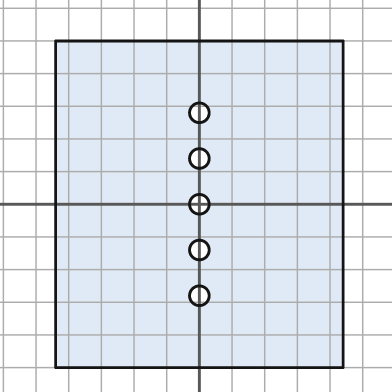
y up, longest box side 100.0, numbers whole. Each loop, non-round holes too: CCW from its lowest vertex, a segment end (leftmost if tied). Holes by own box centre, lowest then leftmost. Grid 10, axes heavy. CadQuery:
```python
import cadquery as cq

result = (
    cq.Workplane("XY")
    .moveTo(-44.0, -50.0)
    .lineTo(44.0, -50.0)
    .lineTo(44.0, 50.0)
    .lineTo(-44.0, 50.0)
    .close()
    .moveTo(0.0, -28.0)
    .circle(3.0)
    .moveTo(0.0, -14.0)
    .circle(3.0)
    .moveTo(0.0, 0.0)
    .circle(3.0)
    .moveTo(0.0, 14.0)
    .circle(3.0)
    .moveTo(0.0, 28.0)
    .circle(3.0)
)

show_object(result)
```